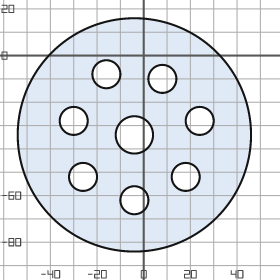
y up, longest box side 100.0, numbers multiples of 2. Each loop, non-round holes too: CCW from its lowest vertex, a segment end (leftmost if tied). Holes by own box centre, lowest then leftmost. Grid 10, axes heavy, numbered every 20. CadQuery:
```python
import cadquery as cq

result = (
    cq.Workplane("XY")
    .moveTo(-4.0, -34.0)
    .circle(50.0)
    .moveTo(-4.0, -62.0)
    .circle(6.0)
    .moveTo(-26.0, -52.0)
    .circle(6.0)
    .moveTo(18.0, -52.0)
    .circle(6.0)
    .moveTo(-4.0, -34.0)
    .circle(8.0)
    .moveTo(-30.0, -28.0)
    .circle(6.0)
    .moveTo(24.0, -28.0)
    .circle(6.0)
    .moveTo(8.0, -10.0)
    .circle(6.0)
    .moveTo(-16.0, -8.0)
    .circle(6.0)
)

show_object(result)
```